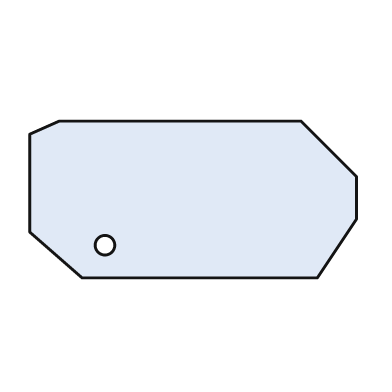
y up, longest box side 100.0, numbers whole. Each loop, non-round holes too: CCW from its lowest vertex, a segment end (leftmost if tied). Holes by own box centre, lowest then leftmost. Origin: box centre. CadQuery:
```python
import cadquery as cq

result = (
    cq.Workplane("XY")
    .moveTo(-34.0, -24.0)
    .lineTo(38.0, -24.0)
    .lineTo(50.0, -6.0)
    .lineTo(50.0, 7.0)
    .lineTo(33.0, 24.0)
    .lineTo(-41.0, 24.0)
    .lineTo(-50.0, 20.0)
    .lineTo(-50.0, -10.0)
    .close()
    .moveTo(-27.0, -14.0)
    .circle(3.0)
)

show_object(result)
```